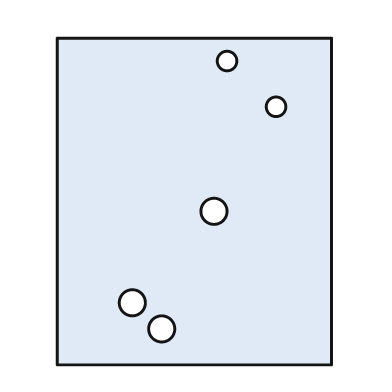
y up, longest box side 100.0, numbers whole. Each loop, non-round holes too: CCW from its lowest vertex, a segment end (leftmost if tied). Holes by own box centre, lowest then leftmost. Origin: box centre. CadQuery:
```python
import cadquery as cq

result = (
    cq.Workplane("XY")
    .moveTo(-42.0, -50.0)
    .lineTo(42.0, -50.0)
    .lineTo(42.0, 50.0)
    .lineTo(-42.0, 50.0)
    .close()
    .moveTo(-10.0, -39.0)
    .circle(4.0)
    .moveTo(-19.0, -31.0)
    .circle(4.0)
    .moveTo(6.0, -3.0)
    .circle(4.0)
    .moveTo(25.0, 29.0)
    .circle(3.0)
    .moveTo(10.0, 43.0)
    .circle(3.0)
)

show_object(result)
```